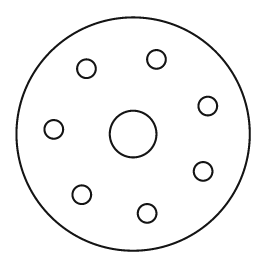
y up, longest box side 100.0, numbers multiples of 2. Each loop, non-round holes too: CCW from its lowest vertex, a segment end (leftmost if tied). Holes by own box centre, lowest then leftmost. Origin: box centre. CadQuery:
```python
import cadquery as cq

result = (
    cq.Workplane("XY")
    .moveTo(0.0, 0.0)
    .circle(50.0)
    .moveTo(6.0, -34.0)
    .circle(4.0)
    .moveTo(-22.0, -26.0)
    .circle(4.0)
    .moveTo(30.0, -16.0)
    .circle(4.0)
    .moveTo(0.0, 0.0)
    .circle(10.0)
    .moveTo(-34.0, 2.0)
    .circle(4.0)
    .moveTo(32.0, 12.0)
    .circle(4.0)
    .moveTo(-20.0, 28.0)
    .circle(4.0)
    .moveTo(10.0, 32.0)
    .circle(4.0)
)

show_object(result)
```